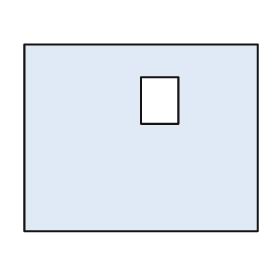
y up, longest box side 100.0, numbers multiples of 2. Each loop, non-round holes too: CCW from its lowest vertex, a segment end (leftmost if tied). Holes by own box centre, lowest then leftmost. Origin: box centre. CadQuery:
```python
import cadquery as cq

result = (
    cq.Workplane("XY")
    .moveTo(-50.0, -40.0)
    .lineTo(50.0, -40.0)
    .lineTo(50.0, 40.0)
    .lineTo(-50.0, 40.0)
    .close()
    .moveTo(0.0, 6.0)
    .lineTo(16.0, 6.0)
    .lineTo(16.0, 26.0)
    .lineTo(0.0, 26.0)
    .close()
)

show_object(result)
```